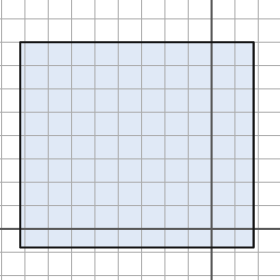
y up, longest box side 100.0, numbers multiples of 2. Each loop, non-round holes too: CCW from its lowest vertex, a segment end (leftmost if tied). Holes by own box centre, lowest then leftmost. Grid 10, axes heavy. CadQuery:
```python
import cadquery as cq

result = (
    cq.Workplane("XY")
    .moveTo(-82.0, -8.0)
    .lineTo(18.0, -8.0)
    .lineTo(18.0, 80.0)
    .lineTo(-82.0, 80.0)
    .close()
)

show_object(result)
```